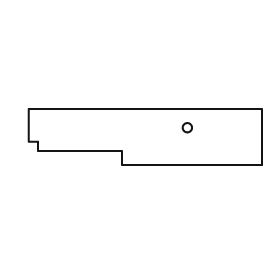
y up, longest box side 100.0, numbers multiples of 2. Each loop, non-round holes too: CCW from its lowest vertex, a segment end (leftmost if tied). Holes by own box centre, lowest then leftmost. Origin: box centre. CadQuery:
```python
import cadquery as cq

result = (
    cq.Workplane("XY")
    .moveTo(-10.0, -12.0)
    .lineTo(50.0, -12.0)
    .lineTo(50.0, 12.0)
    .lineTo(-50.0, 12.0)
    .lineTo(-50.0, -2.0)
    .lineTo(-46.0, -2.0)
    .lineTo(-46.0, -6.0)
    .lineTo(-10.0, -6.0)
    .close()
    .moveTo(18.0, 4.0)
    .circle(2.0)
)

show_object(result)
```